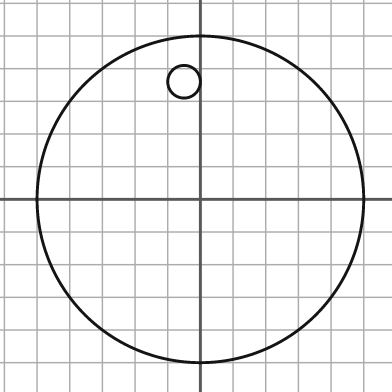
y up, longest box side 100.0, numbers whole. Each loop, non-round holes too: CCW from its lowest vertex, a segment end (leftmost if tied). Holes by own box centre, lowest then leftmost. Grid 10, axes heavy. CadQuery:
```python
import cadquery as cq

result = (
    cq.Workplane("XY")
    .moveTo(0.0, 0.0)
    .circle(50.0)
    .moveTo(-5.0, 36.0)
    .circle(5.0)
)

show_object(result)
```